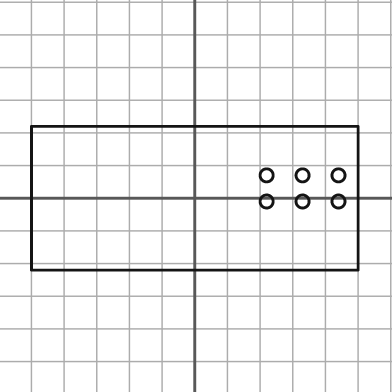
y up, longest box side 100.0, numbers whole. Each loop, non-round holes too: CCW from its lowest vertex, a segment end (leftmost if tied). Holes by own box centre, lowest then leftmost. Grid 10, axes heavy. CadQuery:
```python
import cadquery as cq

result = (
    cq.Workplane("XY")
    .moveTo(-50.0, -22.0)
    .lineTo(50.0, -22.0)
    .lineTo(50.0, 22.0)
    .lineTo(-50.0, 22.0)
    .close()
    .moveTo(22.0, -1.0)
    .circle(2.0)
    .moveTo(33.0, -1.0)
    .circle(2.0)
    .moveTo(44.0, -1.0)
    .circle(2.0)
    .moveTo(22.0, 7.0)
    .circle(2.0)
    .moveTo(33.0, 7.0)
    .circle(2.0)
    .moveTo(44.0, 7.0)
    .circle(2.0)
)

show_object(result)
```